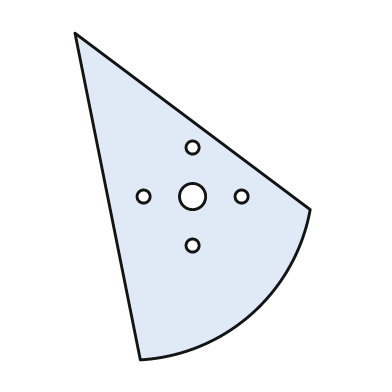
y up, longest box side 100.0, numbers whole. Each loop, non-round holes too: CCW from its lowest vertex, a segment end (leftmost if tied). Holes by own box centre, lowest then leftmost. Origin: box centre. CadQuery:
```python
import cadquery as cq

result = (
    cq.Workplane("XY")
    .moveTo(-16.0, -50.0)
    .threePointArc((18.0, -36.0), (36.0, -4.0))
    .lineTo(-36.0, 50.0)
    .close()
    .moveTo(0.0, -15.0)
    .circle(2.0)
    .moveTo(-15.0, 0.0)
    .circle(2.0)
    .moveTo(0.0, 0.0)
    .circle(4.0)
    .moveTo(15.0, 0.0)
    .circle(2.0)
    .moveTo(0.0, 15.0)
    .circle(2.0)
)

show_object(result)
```